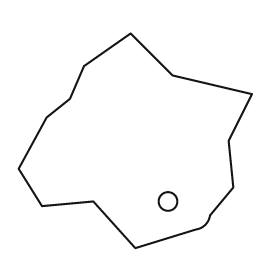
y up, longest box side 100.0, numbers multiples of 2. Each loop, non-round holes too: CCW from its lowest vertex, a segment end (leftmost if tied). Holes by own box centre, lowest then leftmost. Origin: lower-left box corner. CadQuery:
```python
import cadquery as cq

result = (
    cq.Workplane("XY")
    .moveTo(50.0, 0.0)
    .lineTo(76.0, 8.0)
    .threePointArc((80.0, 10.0), (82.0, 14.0))
    .lineTo(92.0, 26.0)
    .lineTo(90.0, 46.0)
    .lineTo(100.0, 66.0)
    .lineTo(66.0, 74.0)
    .lineTo(48.0, 92.0)
    .lineTo(28.0, 78.0)
    .lineTo(22.0, 64.0)
    .lineTo(12.0, 56.0)
    .lineTo(0.0, 34.0)
    .lineTo(10.0, 18.0)
    .lineTo(32.0, 20.0)
    .close()
    .moveTo(64.0, 20.0)
    .circle(4.0)
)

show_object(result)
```